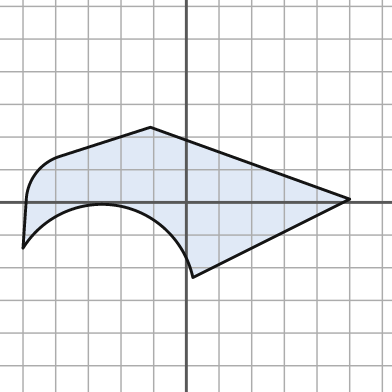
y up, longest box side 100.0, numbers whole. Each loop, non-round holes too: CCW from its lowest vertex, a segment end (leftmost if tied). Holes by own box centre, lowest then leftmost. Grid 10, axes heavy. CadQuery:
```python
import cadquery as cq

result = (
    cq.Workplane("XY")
    .moveTo(2.0, -23.0)
    .lineTo(50.0, 1.0)
    .lineTo(-11.0, 23.0)
    .lineTo(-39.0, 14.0)
    .threePointArc((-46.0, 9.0), (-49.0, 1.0))
    .lineTo(-50.0, -14.0)
    .threePointArc((-21.0, -1.0), (2.0, -23.0))
    .close()
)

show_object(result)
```